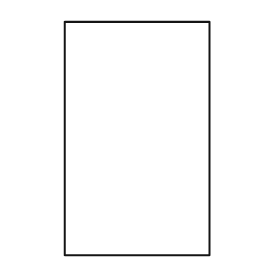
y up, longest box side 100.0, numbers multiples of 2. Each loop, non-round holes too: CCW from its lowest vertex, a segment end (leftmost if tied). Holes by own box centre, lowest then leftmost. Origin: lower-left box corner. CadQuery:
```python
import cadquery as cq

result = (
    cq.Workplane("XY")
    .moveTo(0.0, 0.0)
    .lineTo(62.0, 0.0)
    .lineTo(62.0, 100.0)
    .lineTo(0.0, 100.0)
    .close()
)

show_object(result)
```